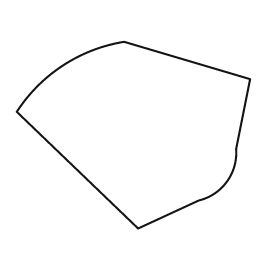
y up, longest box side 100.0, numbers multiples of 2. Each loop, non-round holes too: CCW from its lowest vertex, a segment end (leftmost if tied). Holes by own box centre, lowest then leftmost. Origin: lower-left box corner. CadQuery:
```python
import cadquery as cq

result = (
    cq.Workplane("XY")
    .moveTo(52.0, 0.0)
    .lineTo(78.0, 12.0)
    .threePointArc((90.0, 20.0), (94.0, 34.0))
    .lineTo(100.0, 64.0)
    .lineTo(46.0, 80.0)
    .threePointArc((20.0, 70.0), (0.0, 50.0))
    .close()
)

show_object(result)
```